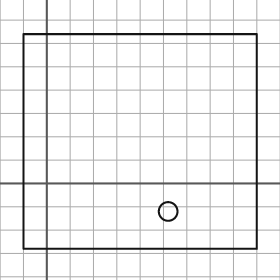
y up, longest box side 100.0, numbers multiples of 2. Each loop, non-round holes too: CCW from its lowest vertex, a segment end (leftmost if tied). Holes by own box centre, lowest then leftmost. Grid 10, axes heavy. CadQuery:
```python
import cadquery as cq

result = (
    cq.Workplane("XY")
    .moveTo(-10.0, -28.0)
    .lineTo(90.0, -28.0)
    .lineTo(90.0, 64.0)
    .lineTo(-10.0, 64.0)
    .close()
    .moveTo(52.0, -12.0)
    .circle(4.0)
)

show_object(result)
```